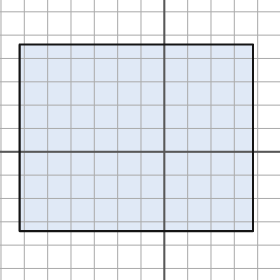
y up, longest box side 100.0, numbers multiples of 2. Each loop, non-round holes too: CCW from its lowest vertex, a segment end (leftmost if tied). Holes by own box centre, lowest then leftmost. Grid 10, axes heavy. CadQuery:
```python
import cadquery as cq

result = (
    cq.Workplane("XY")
    .moveTo(-62.0, -34.0)
    .lineTo(38.0, -34.0)
    .lineTo(38.0, 46.0)
    .lineTo(-62.0, 46.0)
    .close()
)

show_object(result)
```